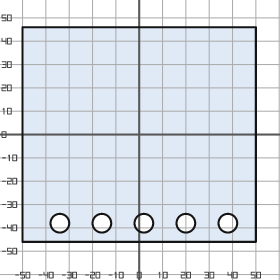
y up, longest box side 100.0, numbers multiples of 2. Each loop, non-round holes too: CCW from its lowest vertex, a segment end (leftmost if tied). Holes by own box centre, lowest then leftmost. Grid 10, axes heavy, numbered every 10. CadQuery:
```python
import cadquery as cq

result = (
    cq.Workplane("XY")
    .moveTo(-50.0, -46.0)
    .lineTo(50.0, -46.0)
    .lineTo(50.0, 46.0)
    .lineTo(-50.0, 46.0)
    .close()
    .moveTo(-34.0, -38.0)
    .circle(4.0)
    .moveTo(-16.0, -38.0)
    .circle(4.0)
    .moveTo(2.0, -38.0)
    .circle(4.0)
    .moveTo(20.0, -38.0)
    .circle(4.0)
    .moveTo(38.0, -38.0)
    .circle(4.0)
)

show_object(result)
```